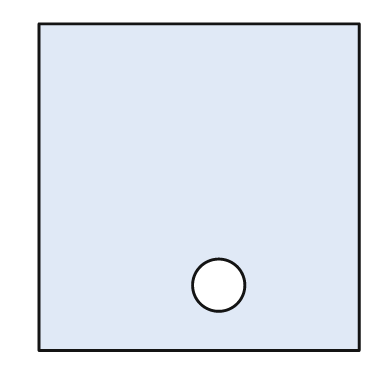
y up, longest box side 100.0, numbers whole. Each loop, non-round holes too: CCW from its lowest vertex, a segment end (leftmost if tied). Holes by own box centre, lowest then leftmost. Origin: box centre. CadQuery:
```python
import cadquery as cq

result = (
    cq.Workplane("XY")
    .moveTo(-49.0, -50.0)
    .lineTo(49.0, -50.0)
    .lineTo(49.0, 50.0)
    .lineTo(-49.0, 50.0)
    .close()
    .moveTo(6.0, -30.0)
    .circle(8.0)
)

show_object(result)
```